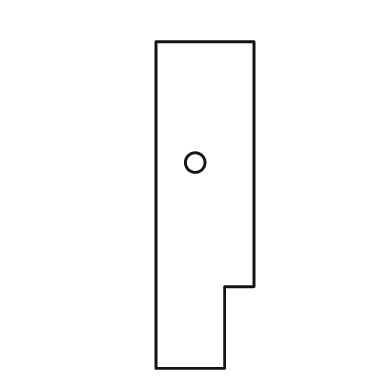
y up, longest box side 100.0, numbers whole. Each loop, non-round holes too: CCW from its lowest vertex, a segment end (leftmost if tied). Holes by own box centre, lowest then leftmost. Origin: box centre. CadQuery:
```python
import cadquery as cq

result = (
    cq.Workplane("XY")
    .moveTo(-15.0, -50.0)
    .lineTo(6.0, -50.0)
    .lineTo(6.0, -25.0)
    .lineTo(15.0, -25.0)
    .lineTo(15.0, 50.0)
    .lineTo(-15.0, 50.0)
    .close()
    .moveTo(-3.0, 13.0)
    .circle(3.0)
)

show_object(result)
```